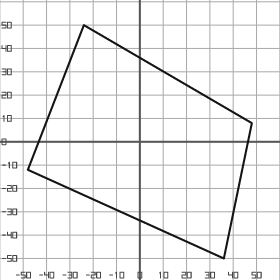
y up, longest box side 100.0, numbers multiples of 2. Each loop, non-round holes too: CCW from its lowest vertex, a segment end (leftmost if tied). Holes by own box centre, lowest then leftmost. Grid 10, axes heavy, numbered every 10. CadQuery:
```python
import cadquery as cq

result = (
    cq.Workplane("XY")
    .moveTo(36.0, -50.0)
    .lineTo(48.0, 8.0)
    .lineTo(-24.0, 50.0)
    .lineTo(-48.0, -12.0)
    .close()
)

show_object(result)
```